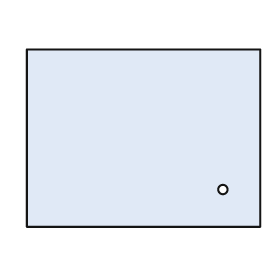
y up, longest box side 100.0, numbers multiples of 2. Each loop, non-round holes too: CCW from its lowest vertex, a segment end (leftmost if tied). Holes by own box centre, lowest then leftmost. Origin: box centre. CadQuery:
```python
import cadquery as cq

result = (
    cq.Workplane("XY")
    .moveTo(-50.0, -38.0)
    .lineTo(50.0, -38.0)
    .lineTo(50.0, 38.0)
    .lineTo(-50.0, 38.0)
    .close()
    .moveTo(34.0, -22.0)
    .circle(2.0)
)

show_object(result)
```